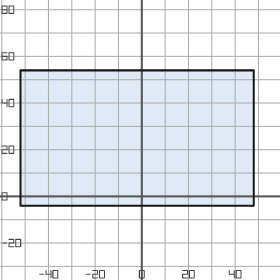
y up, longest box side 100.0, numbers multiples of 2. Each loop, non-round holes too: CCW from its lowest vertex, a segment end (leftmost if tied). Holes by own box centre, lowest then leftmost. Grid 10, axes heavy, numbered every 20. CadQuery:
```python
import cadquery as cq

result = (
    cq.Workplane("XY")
    .moveTo(-52.0, -4.0)
    .lineTo(48.0, -4.0)
    .lineTo(48.0, 54.0)
    .lineTo(-52.0, 54.0)
    .close()
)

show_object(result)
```